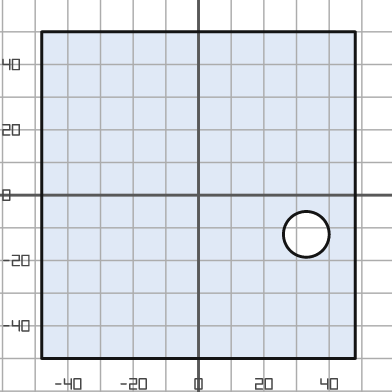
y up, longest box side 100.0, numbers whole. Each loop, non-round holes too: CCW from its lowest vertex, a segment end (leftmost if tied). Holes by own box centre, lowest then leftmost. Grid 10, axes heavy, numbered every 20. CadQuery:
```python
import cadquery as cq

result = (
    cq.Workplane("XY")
    .moveTo(-48.0, -50.0)
    .lineTo(48.0, -50.0)
    .lineTo(48.0, 50.0)
    .lineTo(-48.0, 50.0)
    .close()
    .moveTo(33.0, -12.0)
    .circle(7.0)
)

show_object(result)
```